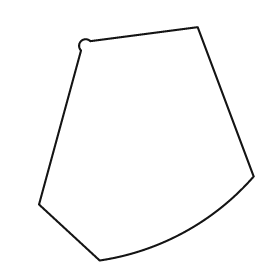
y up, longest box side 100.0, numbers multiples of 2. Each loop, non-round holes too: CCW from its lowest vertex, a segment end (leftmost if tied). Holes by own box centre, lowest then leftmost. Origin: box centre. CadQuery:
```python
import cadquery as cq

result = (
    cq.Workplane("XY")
    .moveTo(-20.0, -50.0)
    .threePointArc((16.0, -38.0), (46.0, -14.0))
    .lineTo(22.0, 50.0)
    .lineTo(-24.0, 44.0)
    .threePointArc((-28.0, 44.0), (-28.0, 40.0))
    .lineTo(-46.0, -26.0)
    .close()
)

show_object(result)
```